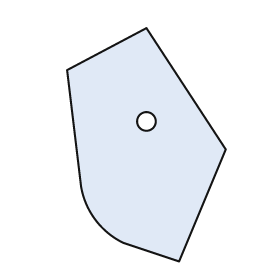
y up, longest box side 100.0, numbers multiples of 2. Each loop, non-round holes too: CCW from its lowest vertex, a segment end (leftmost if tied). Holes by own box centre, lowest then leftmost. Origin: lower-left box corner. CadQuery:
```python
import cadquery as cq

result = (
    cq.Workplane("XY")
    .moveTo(48.0, 0.0)
    .lineTo(68.0, 48.0)
    .lineTo(34.0, 100.0)
    .lineTo(0.0, 82.0)
    .lineTo(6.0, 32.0)
    .threePointArc((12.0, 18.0), (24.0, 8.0))
    .close()
    .moveTo(34.0, 60.0)
    .circle(4.0)
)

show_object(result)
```